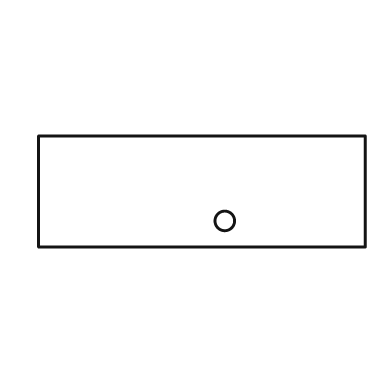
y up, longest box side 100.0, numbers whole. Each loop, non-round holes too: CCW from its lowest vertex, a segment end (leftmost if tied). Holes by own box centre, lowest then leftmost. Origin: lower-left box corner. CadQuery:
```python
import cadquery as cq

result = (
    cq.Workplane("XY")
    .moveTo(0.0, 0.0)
    .lineTo(100.0, 0.0)
    .lineTo(100.0, 34.0)
    .lineTo(0.0, 34.0)
    .close()
    .moveTo(57.0, 8.0)
    .circle(3.0)
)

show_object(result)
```